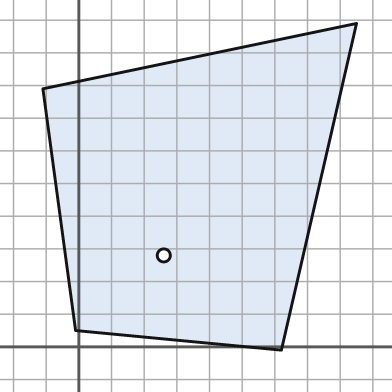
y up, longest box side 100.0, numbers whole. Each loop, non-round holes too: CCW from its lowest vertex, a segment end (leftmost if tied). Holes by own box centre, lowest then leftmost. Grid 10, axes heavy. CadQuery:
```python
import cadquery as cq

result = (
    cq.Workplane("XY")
    .moveTo(62.0, -1.0)
    .lineTo(85.0, 99.0)
    .lineTo(-11.0, 79.0)
    .lineTo(-1.0, 5.0)
    .close()
    .moveTo(26.0, 28.0)
    .circle(2.0)
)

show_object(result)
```